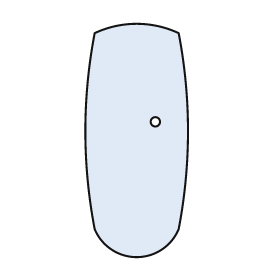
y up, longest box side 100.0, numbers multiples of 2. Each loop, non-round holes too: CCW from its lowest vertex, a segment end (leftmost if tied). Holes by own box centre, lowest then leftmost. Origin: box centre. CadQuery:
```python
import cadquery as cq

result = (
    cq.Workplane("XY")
    .moveTo(-18.0, -38.0)
    .threePointArc((0.0, -50.0), (18.0, -38.0))
    .threePointArc((22.0, 4.0), (18.0, 46.0))
    .threePointArc((0.0, 50.0), (-18.0, 46.0))
    .threePointArc((-22.0, 4.0), (-18.0, -38.0))
    .close()
    .moveTo(8.0, 8.0)
    .circle(2.0)
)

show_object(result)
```